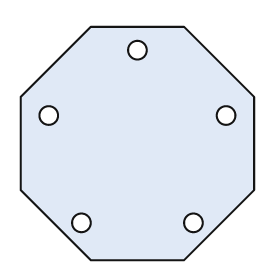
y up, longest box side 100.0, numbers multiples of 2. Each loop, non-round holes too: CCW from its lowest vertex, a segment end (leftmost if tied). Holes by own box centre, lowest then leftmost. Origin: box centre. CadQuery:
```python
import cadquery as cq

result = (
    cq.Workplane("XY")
    .moveTo(-20.0, -50.0)
    .lineTo(20.0, -50.0)
    .lineTo(50.0, -20.0)
    .lineTo(50.0, 20.0)
    .lineTo(20.0, 50.0)
    .lineTo(-20.0, 50.0)
    .lineTo(-50.0, 20.0)
    .lineTo(-50.0, -20.0)
    .close()
    .moveTo(-24.0, -34.0)
    .circle(4.0)
    .moveTo(24.0, -34.0)
    .circle(4.0)
    .moveTo(-38.0, 12.0)
    .circle(4.0)
    .moveTo(38.0, 12.0)
    .circle(4.0)
    .moveTo(0.0, 40.0)
    .circle(4.0)
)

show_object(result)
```